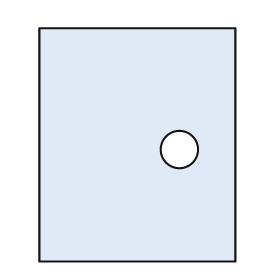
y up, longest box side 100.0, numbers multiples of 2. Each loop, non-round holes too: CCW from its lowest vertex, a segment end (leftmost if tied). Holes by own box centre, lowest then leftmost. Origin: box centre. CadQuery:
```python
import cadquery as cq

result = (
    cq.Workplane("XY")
    .moveTo(-42.0, -50.0)
    .lineTo(42.0, -50.0)
    .lineTo(42.0, 50.0)
    .lineTo(-42.0, 50.0)
    .close()
    .moveTo(18.0, -2.0)
    .circle(8.0)
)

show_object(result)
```